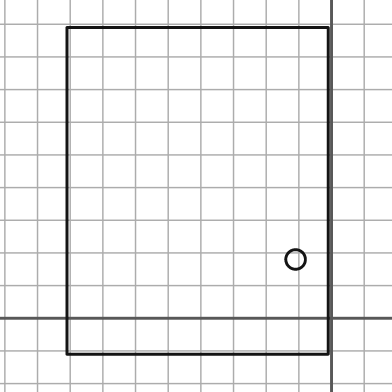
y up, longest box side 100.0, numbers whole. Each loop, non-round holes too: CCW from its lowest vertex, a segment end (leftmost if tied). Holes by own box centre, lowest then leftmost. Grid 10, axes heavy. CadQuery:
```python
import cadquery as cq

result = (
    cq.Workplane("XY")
    .moveTo(-81.0, -11.0)
    .lineTo(-1.0, -11.0)
    .lineTo(-1.0, 89.0)
    .lineTo(-81.0, 89.0)
    .close()
    .moveTo(-11.0, 18.0)
    .circle(3.0)
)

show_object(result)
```